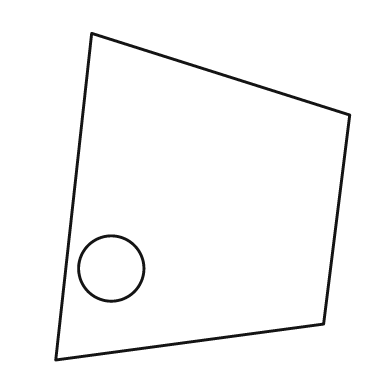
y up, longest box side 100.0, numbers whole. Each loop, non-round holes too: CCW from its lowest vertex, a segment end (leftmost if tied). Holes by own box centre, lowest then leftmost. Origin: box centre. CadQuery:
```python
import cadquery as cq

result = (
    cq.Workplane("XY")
    .moveTo(-45.0, -50.0)
    .lineTo(37.0, -39.0)
    .lineTo(45.0, 25.0)
    .lineTo(-34.0, 50.0)
    .close()
    .moveTo(-28.0, -22.0)
    .circle(10.0)
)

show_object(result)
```